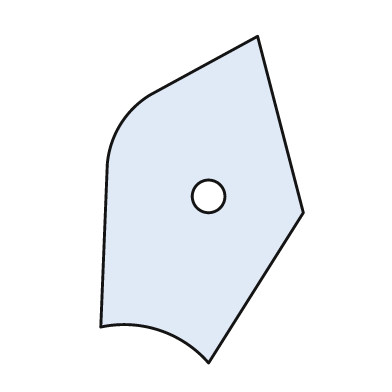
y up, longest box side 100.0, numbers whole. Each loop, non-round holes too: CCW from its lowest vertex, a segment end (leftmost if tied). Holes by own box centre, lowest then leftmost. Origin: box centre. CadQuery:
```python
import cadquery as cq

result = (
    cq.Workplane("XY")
    .moveTo(2.0, -50.0)
    .lineTo(31.0, -4.0)
    .lineTo(17.0, 50.0)
    .lineTo(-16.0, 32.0)
    .threePointArc((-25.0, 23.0), (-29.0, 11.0))
    .lineTo(-31.0, -39.0)
    .threePointArc((-13.0, -40.0), (2.0, -50.0))
    .close()
    .moveTo(2.0, 1.0)
    .circle(5.0)
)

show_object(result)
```